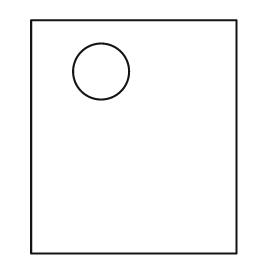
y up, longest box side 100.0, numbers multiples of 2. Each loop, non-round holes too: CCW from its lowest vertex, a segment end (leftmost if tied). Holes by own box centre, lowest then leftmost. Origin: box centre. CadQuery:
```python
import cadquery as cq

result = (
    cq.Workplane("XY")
    .moveTo(-44.0, -50.0)
    .lineTo(44.0, -50.0)
    .lineTo(44.0, 50.0)
    .lineTo(-44.0, 50.0)
    .close()
    .moveTo(-14.0, 28.0)
    .circle(12.0)
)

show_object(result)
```